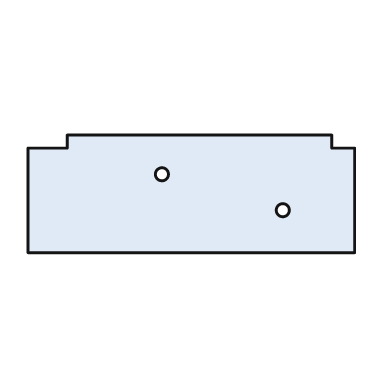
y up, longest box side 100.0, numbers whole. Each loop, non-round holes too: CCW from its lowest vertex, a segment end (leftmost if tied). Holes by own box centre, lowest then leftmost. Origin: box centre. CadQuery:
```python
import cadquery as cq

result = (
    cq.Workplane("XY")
    .moveTo(-50.0, -18.0)
    .lineTo(50.0, -18.0)
    .lineTo(50.0, 14.0)
    .lineTo(43.0, 14.0)
    .lineTo(43.0, 18.0)
    .lineTo(-38.0, 18.0)
    .lineTo(-38.0, 14.0)
    .lineTo(-50.0, 14.0)
    .close()
    .moveTo(28.0, -5.0)
    .circle(2.0)
    .moveTo(-9.0, 6.0)
    .circle(2.0)
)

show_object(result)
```